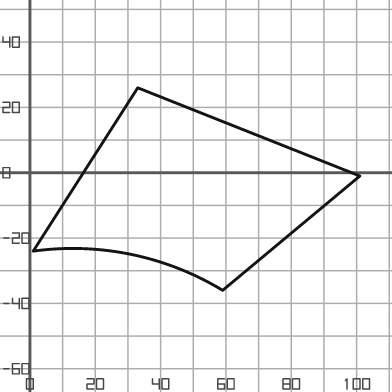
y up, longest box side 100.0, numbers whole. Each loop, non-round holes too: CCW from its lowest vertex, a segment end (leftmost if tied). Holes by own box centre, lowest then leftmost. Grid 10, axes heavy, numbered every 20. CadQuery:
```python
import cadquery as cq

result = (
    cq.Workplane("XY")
    .moveTo(59.0, -36.0)
    .lineTo(101.0, -1.0)
    .lineTo(33.0, 26.0)
    .lineTo(1.0, -24.0)
    .threePointArc((31.0, -25.0), (59.0, -36.0))
    .close()
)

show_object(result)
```